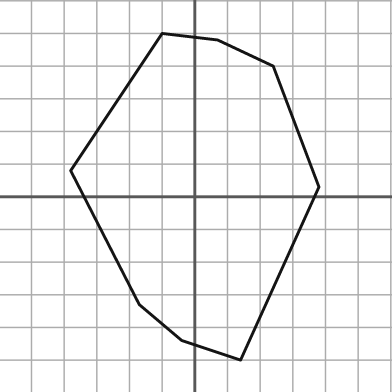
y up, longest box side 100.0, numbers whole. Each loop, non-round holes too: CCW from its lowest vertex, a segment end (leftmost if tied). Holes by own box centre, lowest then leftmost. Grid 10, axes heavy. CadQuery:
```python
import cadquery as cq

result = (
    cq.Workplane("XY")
    .moveTo(14.0, -50.0)
    .lineTo(38.0, 3.0)
    .lineTo(24.0, 40.0)
    .lineTo(7.0, 48.0)
    .lineTo(-10.0, 50.0)
    .lineTo(-38.0, 8.0)
    .lineTo(-17.0, -33.0)
    .lineTo(-4.0, -44.0)
    .close()
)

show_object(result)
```